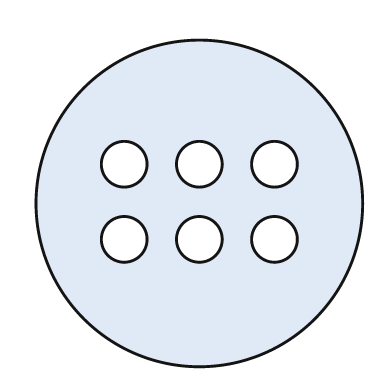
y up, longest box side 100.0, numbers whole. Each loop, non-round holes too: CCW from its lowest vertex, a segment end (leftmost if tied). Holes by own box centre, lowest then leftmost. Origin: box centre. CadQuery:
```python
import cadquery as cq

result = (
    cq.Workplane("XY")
    .moveTo(0.0, 0.0)
    .circle(50.0)
    .moveTo(-23.0, -11.0)
    .circle(7.0)
    .moveTo(0.0, -11.0)
    .circle(7.0)
    .moveTo(23.0, -11.0)
    .circle(7.0)
    .moveTo(-23.0, 12.0)
    .circle(7.0)
    .moveTo(0.0, 12.0)
    .circle(7.0)
    .moveTo(23.0, 12.0)
    .circle(7.0)
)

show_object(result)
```